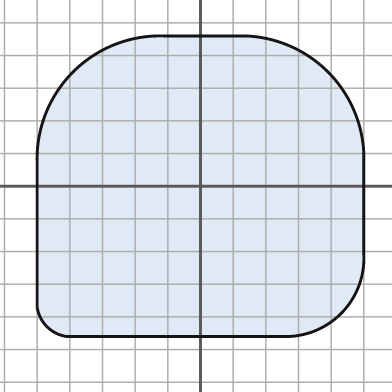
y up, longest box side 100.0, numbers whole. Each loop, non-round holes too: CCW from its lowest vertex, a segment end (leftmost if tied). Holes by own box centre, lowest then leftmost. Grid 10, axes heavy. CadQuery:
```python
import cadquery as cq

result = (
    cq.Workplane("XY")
    .moveTo(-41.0, -46.0)
    .lineTo(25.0, -46.0)
    .threePointArc((43.0, -39.0), (50.0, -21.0))
    .lineTo(50.0, 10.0)
    .threePointArc((39.0, 35.0), (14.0, 46.0))
    .lineTo(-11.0, 46.0)
    .threePointArc((-39.0, 35.0), (-50.0, 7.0))
    .lineTo(-50.0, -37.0)
    .threePointArc((-47.0, -43.0), (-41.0, -46.0))
    .close()
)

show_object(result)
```